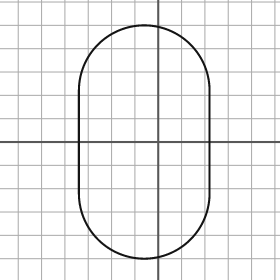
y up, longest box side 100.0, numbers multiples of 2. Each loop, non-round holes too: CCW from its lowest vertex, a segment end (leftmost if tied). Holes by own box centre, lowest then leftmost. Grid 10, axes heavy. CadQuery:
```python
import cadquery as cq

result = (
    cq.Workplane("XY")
    .moveTo(-34.0, -22.0)
    .threePointArc((-6.0, -50.0), (22.0, -22.0))
    .lineTo(22.0, 22.0)
    .threePointArc((-6.0, 50.0), (-34.0, 22.0))
    .close()
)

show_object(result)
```